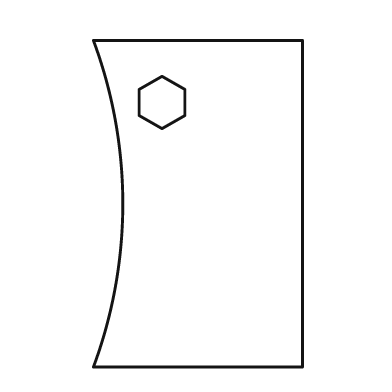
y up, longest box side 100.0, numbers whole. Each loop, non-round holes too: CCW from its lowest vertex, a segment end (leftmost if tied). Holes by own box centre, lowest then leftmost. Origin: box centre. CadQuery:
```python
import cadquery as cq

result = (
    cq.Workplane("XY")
    .moveTo(-32.0, -50.0)
    .lineTo(32.0, -50.0)
    .lineTo(32.0, 50.0)
    .lineTo(-32.0, 50.0)
    .threePointArc((-23.0, 0.0), (-32.0, -50.0))
    .close()
    .moveTo(-11.0, 23.0)
    .lineTo(-4.0, 27.0)
    .lineTo(-4.0, 35.0)
    .lineTo(-11.0, 39.0)
    .lineTo(-18.0, 35.0)
    .lineTo(-18.0, 27.0)
    .close()
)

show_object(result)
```